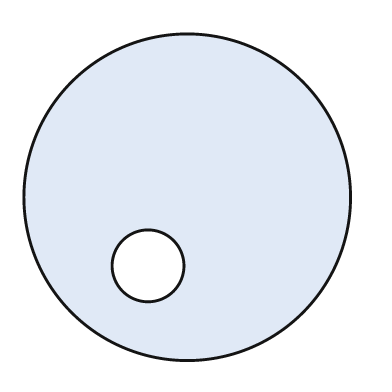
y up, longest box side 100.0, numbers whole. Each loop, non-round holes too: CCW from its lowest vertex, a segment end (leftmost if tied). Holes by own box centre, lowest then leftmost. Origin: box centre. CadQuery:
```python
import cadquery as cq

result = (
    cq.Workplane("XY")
    .moveTo(0.0, 0.0)
    .circle(50.0)
    .moveTo(-12.0, -21.0)
    .circle(11.0)
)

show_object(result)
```